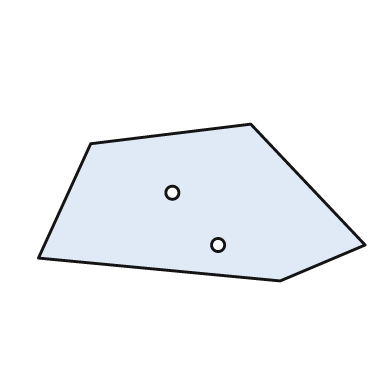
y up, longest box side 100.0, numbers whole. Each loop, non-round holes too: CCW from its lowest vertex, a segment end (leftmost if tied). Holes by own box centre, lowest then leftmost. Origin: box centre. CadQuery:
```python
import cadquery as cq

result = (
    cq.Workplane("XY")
    .moveTo(24.0, -24.0)
    .lineTo(50.0, -13.0)
    .lineTo(15.0, 24.0)
    .lineTo(-34.0, 18.0)
    .lineTo(-50.0, -17.0)
    .close()
    .moveTo(5.0, -13.0)
    .circle(2.0)
    .moveTo(-9.0, 3.0)
    .circle(2.0)
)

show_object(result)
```